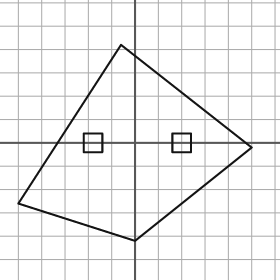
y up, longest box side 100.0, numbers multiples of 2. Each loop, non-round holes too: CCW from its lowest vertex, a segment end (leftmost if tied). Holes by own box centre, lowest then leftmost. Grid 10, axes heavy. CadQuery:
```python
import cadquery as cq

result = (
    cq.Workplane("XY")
    .moveTo(0.0, -42.0)
    .lineTo(50.0, -2.0)
    .lineTo(-6.0, 42.0)
    .lineTo(-50.0, -26.0)
    .close()
    .moveTo(-22.0, -4.0)
    .lineTo(-14.0, -4.0)
    .lineTo(-14.0, 4.0)
    .lineTo(-22.0, 4.0)
    .close()
    .moveTo(16.0, -4.0)
    .lineTo(24.0, -4.0)
    .lineTo(24.0, 4.0)
    .lineTo(16.0, 4.0)
    .close()
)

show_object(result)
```